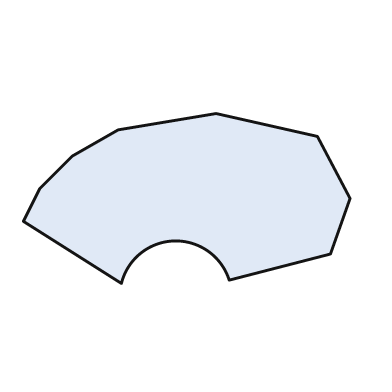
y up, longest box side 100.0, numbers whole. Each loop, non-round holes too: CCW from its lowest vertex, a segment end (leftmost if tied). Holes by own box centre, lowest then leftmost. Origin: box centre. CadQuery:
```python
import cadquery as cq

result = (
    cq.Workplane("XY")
    .moveTo(-20.0, -26.0)
    .threePointArc((-4.0, -13.0), (13.0, -25.0))
    .lineTo(44.0, -17.0)
    .lineTo(50.0, 0.0)
    .lineTo(40.0, 19.0)
    .lineTo(9.0, 26.0)
    .lineTo(-21.0, 21.0)
    .lineTo(-35.0, 13.0)
    .lineTo(-45.0, 3.0)
    .lineTo(-50.0, -7.0)
    .close()
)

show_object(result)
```